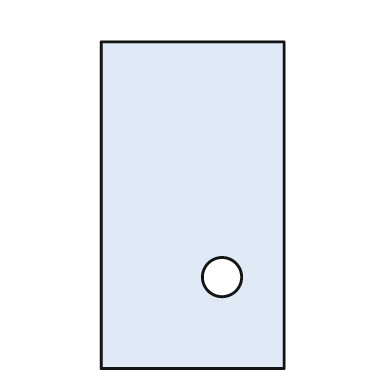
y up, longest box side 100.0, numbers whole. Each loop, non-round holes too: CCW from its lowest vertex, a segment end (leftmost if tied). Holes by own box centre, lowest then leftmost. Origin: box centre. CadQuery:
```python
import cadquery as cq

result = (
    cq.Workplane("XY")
    .moveTo(-28.0, -50.0)
    .lineTo(28.0, -50.0)
    .lineTo(28.0, 50.0)
    .lineTo(-28.0, 50.0)
    .close()
    .moveTo(9.0, -22.0)
    .circle(6.0)
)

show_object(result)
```